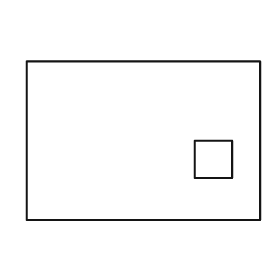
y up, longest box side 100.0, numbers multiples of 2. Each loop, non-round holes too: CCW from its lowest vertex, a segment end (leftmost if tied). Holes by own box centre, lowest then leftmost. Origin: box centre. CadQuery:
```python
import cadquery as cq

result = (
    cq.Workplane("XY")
    .moveTo(-50.0, -34.0)
    .lineTo(50.0, -34.0)
    .lineTo(50.0, 34.0)
    .lineTo(-50.0, 34.0)
    .close()
    .moveTo(22.0, -16.0)
    .lineTo(38.0, -16.0)
    .lineTo(38.0, 0.0)
    .lineTo(22.0, 0.0)
    .close()
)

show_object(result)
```